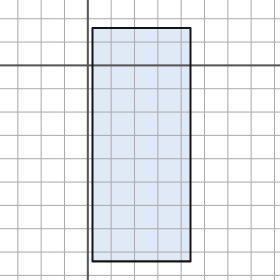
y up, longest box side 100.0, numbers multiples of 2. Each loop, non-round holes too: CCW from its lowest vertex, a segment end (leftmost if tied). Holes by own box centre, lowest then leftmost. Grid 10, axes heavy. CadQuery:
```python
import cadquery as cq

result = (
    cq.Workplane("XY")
    .moveTo(2.0, -84.0)
    .lineTo(44.0, -84.0)
    .lineTo(44.0, 16.0)
    .lineTo(2.0, 16.0)
    .close()
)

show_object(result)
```